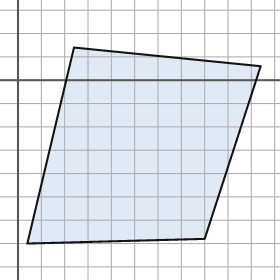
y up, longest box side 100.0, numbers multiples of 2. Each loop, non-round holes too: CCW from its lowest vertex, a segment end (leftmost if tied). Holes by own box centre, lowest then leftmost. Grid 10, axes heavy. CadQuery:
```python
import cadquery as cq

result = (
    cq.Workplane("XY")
    .moveTo(4.0, -70.0)
    .lineTo(80.0, -68.0)
    .lineTo(104.0, 6.0)
    .lineTo(24.0, 14.0)
    .close()
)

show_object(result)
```